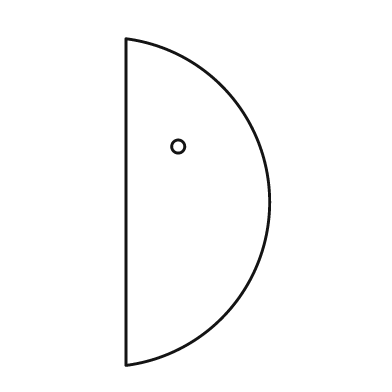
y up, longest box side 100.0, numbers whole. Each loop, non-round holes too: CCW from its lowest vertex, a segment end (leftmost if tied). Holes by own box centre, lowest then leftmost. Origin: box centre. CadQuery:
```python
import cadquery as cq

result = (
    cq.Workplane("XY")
    .moveTo(-22.0, -50.0)
    .threePointArc((22.0, 0.0), (-22.0, 50.0))
    .close()
    .moveTo(-6.0, 17.0)
    .circle(2.0)
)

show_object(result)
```